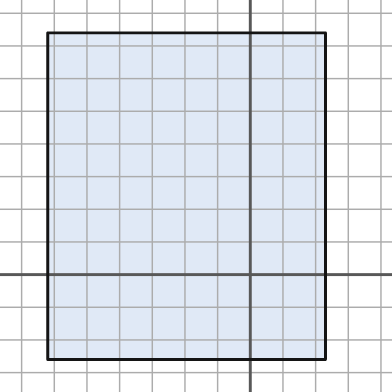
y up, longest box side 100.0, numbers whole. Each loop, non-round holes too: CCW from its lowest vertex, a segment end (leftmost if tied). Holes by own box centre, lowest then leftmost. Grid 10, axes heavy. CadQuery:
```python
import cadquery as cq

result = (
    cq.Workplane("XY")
    .moveTo(-62.0, -26.0)
    .lineTo(23.0, -26.0)
    .lineTo(23.0, 74.0)
    .lineTo(-62.0, 74.0)
    .close()
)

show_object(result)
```